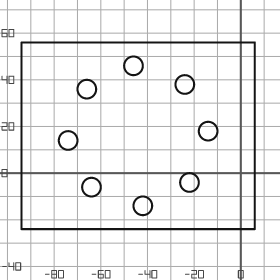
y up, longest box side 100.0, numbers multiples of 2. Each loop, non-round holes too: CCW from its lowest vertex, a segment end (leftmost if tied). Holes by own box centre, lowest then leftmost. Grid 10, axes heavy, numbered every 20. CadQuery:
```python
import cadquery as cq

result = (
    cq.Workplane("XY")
    .moveTo(-94.0, -24.0)
    .lineTo(6.0, -24.0)
    .lineTo(6.0, 56.0)
    .lineTo(-94.0, 56.0)
    .close()
    .moveTo(-42.0, -14.0)
    .circle(4.0)
    .moveTo(-64.0, -6.0)
    .circle(4.0)
    .moveTo(-22.0, -4.0)
    .circle(4.0)
    .moveTo(-74.0, 14.0)
    .circle(4.0)
    .moveTo(-14.0, 18.0)
    .circle(4.0)
    .moveTo(-66.0, 36.0)
    .circle(4.0)
    .moveTo(-24.0, 38.0)
    .circle(4.0)
    .moveTo(-46.0, 46.0)
    .circle(4.0)
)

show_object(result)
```